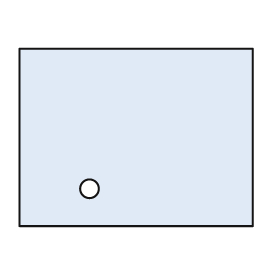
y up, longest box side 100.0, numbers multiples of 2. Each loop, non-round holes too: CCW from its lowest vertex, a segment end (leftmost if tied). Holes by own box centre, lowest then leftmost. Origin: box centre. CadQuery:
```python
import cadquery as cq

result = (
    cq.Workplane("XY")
    .moveTo(-50.0, -38.0)
    .lineTo(50.0, -38.0)
    .lineTo(50.0, 38.0)
    .lineTo(-50.0, 38.0)
    .close()
    .moveTo(-20.0, -22.0)
    .circle(4.0)
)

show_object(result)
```